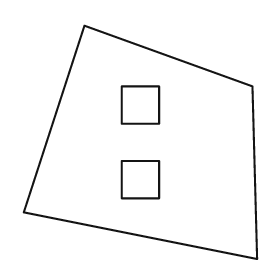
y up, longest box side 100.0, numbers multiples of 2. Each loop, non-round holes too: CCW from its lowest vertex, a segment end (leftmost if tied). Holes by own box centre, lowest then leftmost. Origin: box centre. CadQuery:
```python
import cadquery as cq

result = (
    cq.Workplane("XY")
    .moveTo(50.0, -50.0)
    .lineTo(48.0, 24.0)
    .lineTo(-24.0, 50.0)
    .lineTo(-50.0, -30.0)
    .close()
    .moveTo(-8.0, -24.0)
    .lineTo(8.0, -24.0)
    .lineTo(8.0, -8.0)
    .lineTo(-8.0, -8.0)
    .close()
    .moveTo(-8.0, 8.0)
    .lineTo(8.0, 8.0)
    .lineTo(8.0, 24.0)
    .lineTo(-8.0, 24.0)
    .close()
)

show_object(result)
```